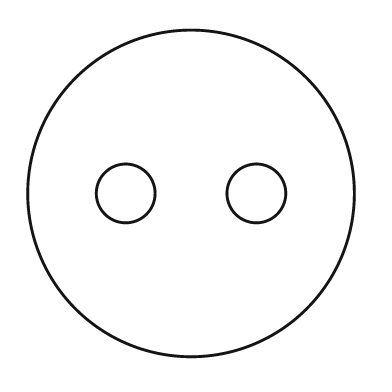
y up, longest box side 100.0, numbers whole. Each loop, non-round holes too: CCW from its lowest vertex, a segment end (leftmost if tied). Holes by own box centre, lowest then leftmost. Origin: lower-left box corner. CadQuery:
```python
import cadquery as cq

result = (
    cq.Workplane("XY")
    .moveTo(50.0, 50.0)
    .circle(50.0)
    .moveTo(30.0, 50.0)
    .circle(9.0)
    .moveTo(70.0, 50.0)
    .circle(9.0)
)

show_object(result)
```